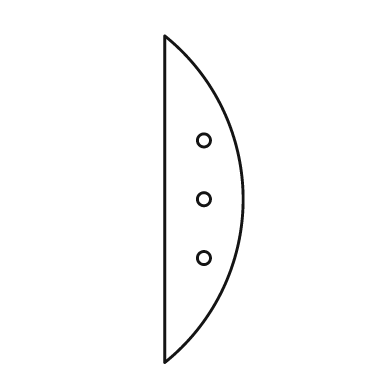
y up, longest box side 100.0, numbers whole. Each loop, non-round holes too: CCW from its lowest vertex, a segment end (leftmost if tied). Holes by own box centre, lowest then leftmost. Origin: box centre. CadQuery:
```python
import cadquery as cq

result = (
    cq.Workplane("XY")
    .moveTo(-12.0, -50.0)
    .threePointArc((12.0, 0.0), (-12.0, 50.0))
    .close()
    .moveTo(0.0, -18.0)
    .circle(2.0)
    .moveTo(0.0, 0.0)
    .circle(2.0)
    .moveTo(0.0, 18.0)
    .circle(2.0)
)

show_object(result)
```